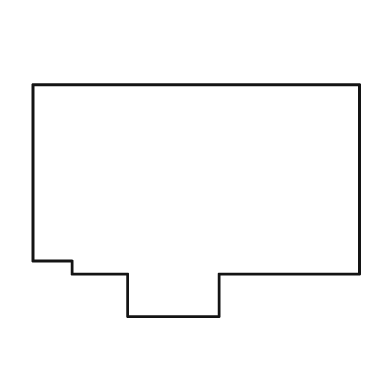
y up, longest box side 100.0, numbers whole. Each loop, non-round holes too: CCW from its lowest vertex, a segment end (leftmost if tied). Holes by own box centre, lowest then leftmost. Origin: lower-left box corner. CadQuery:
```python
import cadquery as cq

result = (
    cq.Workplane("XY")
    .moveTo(29.0, 0.0)
    .lineTo(57.0, 0.0)
    .lineTo(57.0, 13.0)
    .lineTo(100.0, 13.0)
    .lineTo(100.0, 71.0)
    .lineTo(0.0, 71.0)
    .lineTo(0.0, 17.0)
    .lineTo(12.0, 17.0)
    .lineTo(12.0, 13.0)
    .lineTo(29.0, 13.0)
    .close()
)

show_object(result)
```